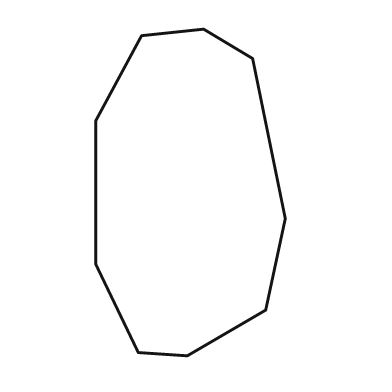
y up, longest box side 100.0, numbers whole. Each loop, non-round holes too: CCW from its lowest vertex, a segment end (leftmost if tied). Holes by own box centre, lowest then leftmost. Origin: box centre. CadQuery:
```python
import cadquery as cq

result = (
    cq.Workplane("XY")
    .moveTo(-1.0, -50.0)
    .lineTo(23.0, -36.0)
    .lineTo(29.0, -8.0)
    .lineTo(19.0, 41.0)
    .lineTo(4.0, 50.0)
    .lineTo(-15.0, 48.0)
    .lineTo(-29.0, 22.0)
    .lineTo(-29.0, -22.0)
    .lineTo(-16.0, -49.0)
    .close()
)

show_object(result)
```